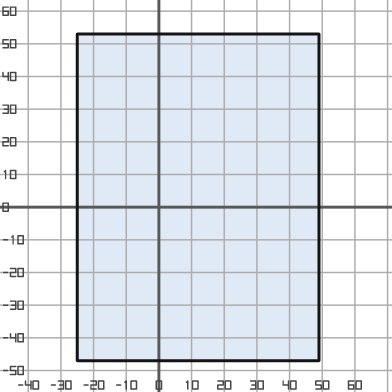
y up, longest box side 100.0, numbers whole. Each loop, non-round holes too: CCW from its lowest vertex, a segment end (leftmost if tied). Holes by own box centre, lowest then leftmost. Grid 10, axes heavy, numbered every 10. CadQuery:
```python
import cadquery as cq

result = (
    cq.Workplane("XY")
    .moveTo(-25.0, -47.0)
    .lineTo(49.0, -47.0)
    .lineTo(49.0, 53.0)
    .lineTo(-25.0, 53.0)
    .close()
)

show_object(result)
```